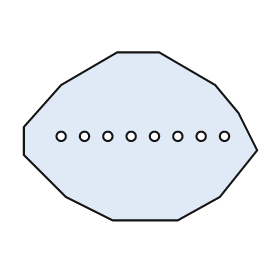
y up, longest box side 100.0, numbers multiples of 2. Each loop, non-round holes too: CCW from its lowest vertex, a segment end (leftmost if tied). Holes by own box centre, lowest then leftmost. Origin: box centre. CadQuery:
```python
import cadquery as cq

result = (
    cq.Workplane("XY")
    .moveTo(-12.0, -36.0)
    .lineTo(16.0, -36.0)
    .lineTo(34.0, -26.0)
    .lineTo(50.0, -6.0)
    .lineTo(42.0, 10.0)
    .lineTo(32.0, 22.0)
    .lineTo(8.0, 36.0)
    .lineTo(-10.0, 36.0)
    .lineTo(-34.0, 22.0)
    .lineTo(-50.0, 4.0)
    .lineTo(-50.0, -8.0)
    .lineTo(-32.0, -26.0)
    .close()
    .moveTo(-34.0, 0.0)
    .circle(2.0)
    .moveTo(-24.0, 0.0)
    .circle(2.0)
    .moveTo(-14.0, 0.0)
    .circle(2.0)
    .moveTo(-4.0, 0.0)
    .circle(2.0)
    .moveTo(6.0, 0.0)
    .circle(2.0)
    .moveTo(16.0, 0.0)
    .circle(2.0)
    .moveTo(26.0, 0.0)
    .circle(2.0)
    .moveTo(36.0, 0.0)
    .circle(2.0)
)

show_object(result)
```